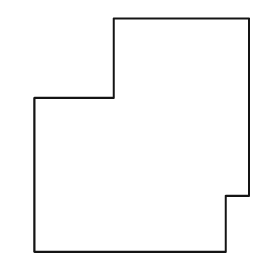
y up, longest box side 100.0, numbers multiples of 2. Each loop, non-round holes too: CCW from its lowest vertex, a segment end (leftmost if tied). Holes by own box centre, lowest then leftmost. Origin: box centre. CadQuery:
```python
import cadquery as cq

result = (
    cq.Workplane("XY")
    .moveTo(-46.0, -50.0)
    .lineTo(36.0, -50.0)
    .lineTo(36.0, -26.0)
    .lineTo(46.0, -26.0)
    .lineTo(46.0, 50.0)
    .lineTo(-12.0, 50.0)
    .lineTo(-12.0, 16.0)
    .lineTo(-46.0, 16.0)
    .close()
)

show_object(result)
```